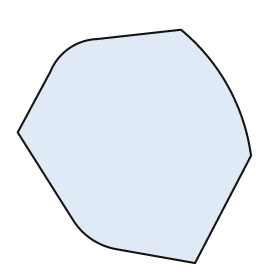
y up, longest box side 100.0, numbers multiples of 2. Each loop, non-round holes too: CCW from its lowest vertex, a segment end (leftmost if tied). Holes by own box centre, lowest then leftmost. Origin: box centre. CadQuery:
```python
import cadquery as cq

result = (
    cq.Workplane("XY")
    .moveTo(26.0, -50.0)
    .lineTo(50.0, -4.0)
    .threePointArc((40.0, 26.0), (20.0, 50.0))
    .lineTo(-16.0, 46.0)
    .threePointArc((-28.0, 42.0), (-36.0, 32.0))
    .lineTo(-50.0, 6.0)
    .lineTo(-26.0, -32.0)
    .threePointArc((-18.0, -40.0), (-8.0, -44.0))
    .close()
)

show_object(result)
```